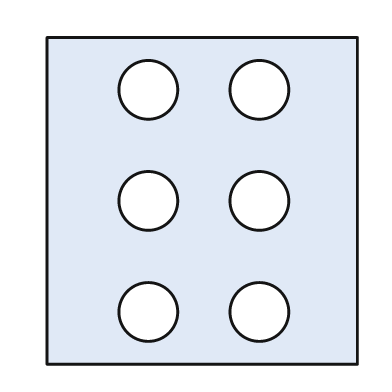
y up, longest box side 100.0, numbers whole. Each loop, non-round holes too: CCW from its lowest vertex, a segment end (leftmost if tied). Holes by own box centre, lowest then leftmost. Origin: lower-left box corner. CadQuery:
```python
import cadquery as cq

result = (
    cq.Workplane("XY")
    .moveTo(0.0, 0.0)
    .lineTo(95.0, 0.0)
    .lineTo(95.0, 100.0)
    .lineTo(0.0, 100.0)
    .close()
    .moveTo(31.0, 16.0)
    .circle(9.0)
    .moveTo(65.0, 16.0)
    .circle(9.0)
    .moveTo(31.0, 50.0)
    .circle(9.0)
    .moveTo(65.0, 50.0)
    .circle(9.0)
    .moveTo(31.0, 84.0)
    .circle(9.0)
    .moveTo(65.0, 84.0)
    .circle(9.0)
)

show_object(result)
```